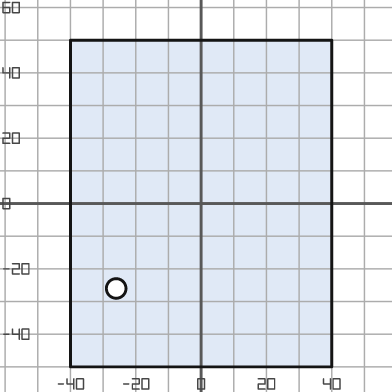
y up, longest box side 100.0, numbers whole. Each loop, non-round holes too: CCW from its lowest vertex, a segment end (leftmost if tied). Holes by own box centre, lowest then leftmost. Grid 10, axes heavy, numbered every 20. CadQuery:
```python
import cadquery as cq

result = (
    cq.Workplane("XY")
    .moveTo(-40.0, -50.0)
    .lineTo(40.0, -50.0)
    .lineTo(40.0, 50.0)
    .lineTo(-40.0, 50.0)
    .close()
    .moveTo(-26.0, -26.0)
    .circle(3.0)
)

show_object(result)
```